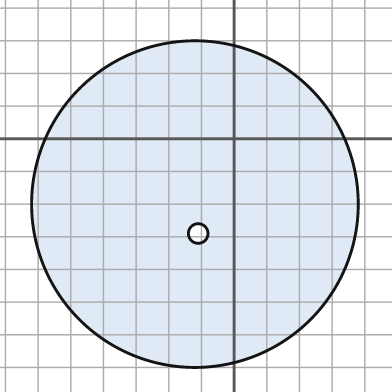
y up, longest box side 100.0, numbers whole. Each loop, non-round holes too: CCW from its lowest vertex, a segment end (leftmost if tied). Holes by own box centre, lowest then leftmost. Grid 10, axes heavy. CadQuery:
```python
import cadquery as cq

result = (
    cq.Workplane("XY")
    .moveTo(-12.0, -20.0)
    .circle(50.0)
    .moveTo(-11.0, -29.0)
    .circle(3.0)
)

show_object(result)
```